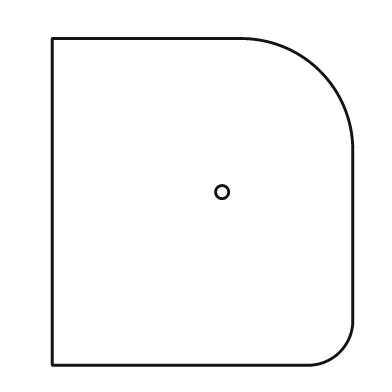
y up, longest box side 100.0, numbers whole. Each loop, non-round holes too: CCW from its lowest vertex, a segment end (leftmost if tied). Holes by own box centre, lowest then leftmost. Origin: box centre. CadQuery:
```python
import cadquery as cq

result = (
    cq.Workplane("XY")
    .moveTo(-46.0, -50.0)
    .lineTo(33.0, -50.0)
    .threePointArc((42.0, -46.0), (46.0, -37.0))
    .lineTo(46.0, 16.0)
    .threePointArc((36.0, 40.0), (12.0, 50.0))
    .lineTo(-46.0, 50.0)
    .close()
    .moveTo(6.0, 3.0)
    .circle(2.0)
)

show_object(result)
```